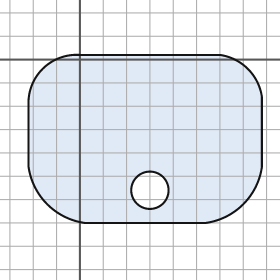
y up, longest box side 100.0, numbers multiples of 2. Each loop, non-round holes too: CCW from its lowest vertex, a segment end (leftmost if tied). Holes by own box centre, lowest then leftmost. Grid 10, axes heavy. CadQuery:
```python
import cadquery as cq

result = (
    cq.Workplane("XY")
    .moveTo(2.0, -70.0)
    .lineTo(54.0, -70.0)
    .threePointArc((70.0, -62.0), (78.0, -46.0))
    .lineTo(78.0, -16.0)
    .threePointArc((72.0, -4.0), (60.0, 2.0))
    .lineTo(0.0, 2.0)
    .threePointArc((-16.0, -4.0), (-22.0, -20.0))
    .lineTo(-22.0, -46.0)
    .threePointArc((-14.0, -62.0), (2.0, -70.0))
    .close()
    .moveTo(30.0, -56.0)
    .circle(8.0)
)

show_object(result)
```